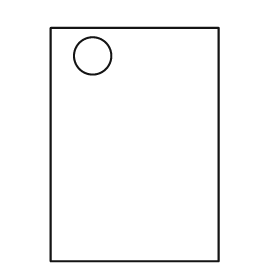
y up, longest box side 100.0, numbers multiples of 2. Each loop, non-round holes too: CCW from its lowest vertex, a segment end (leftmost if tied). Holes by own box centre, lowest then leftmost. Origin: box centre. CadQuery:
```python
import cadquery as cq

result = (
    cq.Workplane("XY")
    .moveTo(-36.0, -50.0)
    .lineTo(36.0, -50.0)
    .lineTo(36.0, 50.0)
    .lineTo(-36.0, 50.0)
    .close()
    .moveTo(-18.0, 38.0)
    .circle(8.0)
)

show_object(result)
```